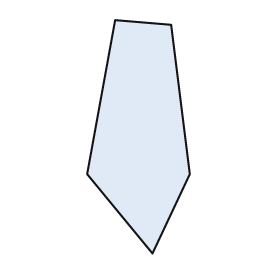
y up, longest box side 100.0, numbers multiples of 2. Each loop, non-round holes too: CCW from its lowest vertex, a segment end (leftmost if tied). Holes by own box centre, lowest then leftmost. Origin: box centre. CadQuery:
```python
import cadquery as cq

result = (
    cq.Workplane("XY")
    .moveTo(6.0, -50.0)
    .lineTo(22.0, -16.0)
    .lineTo(14.0, 48.0)
    .lineTo(-10.0, 50.0)
    .lineTo(-22.0, -16.0)
    .close()
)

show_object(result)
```